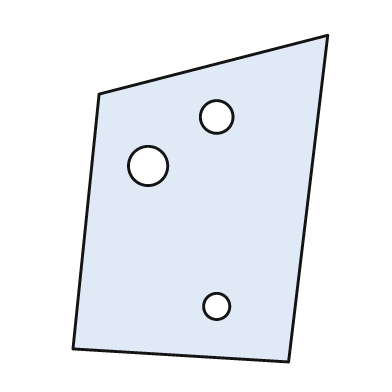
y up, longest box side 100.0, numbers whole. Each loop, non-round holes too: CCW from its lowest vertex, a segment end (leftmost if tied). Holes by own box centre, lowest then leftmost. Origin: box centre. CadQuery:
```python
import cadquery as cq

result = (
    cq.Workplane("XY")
    .moveTo(27.0, -50.0)
    .lineTo(39.0, 50.0)
    .lineTo(-31.0, 32.0)
    .lineTo(-39.0, -46.0)
    .close()
    .moveTo(5.0, -33.0)
    .circle(4.0)
    .moveTo(-16.0, 10.0)
    .circle(6.0)
    .moveTo(5.0, 25.0)
    .circle(5.0)
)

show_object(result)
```